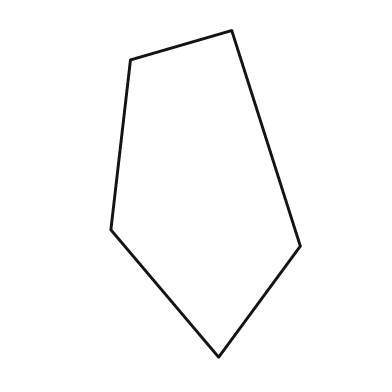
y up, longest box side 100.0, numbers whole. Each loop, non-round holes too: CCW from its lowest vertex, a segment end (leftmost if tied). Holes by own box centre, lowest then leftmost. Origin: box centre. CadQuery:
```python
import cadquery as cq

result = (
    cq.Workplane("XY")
    .moveTo(4.0, -50.0)
    .lineTo(29.0, -16.0)
    .lineTo(8.0, 50.0)
    .lineTo(-23.0, 41.0)
    .lineTo(-29.0, -11.0)
    .close()
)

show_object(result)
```